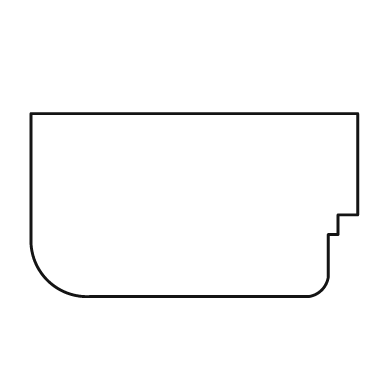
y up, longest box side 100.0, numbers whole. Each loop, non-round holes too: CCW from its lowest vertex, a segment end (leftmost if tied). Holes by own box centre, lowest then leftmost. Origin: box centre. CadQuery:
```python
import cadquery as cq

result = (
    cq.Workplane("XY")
    .moveTo(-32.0, -28.0)
    .lineTo(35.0, -28.0)
    .threePointArc((39.0, -26.0), (41.0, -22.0))
    .lineTo(41.0, -9.0)
    .lineTo(44.0, -9.0)
    .lineTo(44.0, -3.0)
    .lineTo(50.0, -3.0)
    .lineTo(50.0, 28.0)
    .lineTo(-50.0, 28.0)
    .lineTo(-50.0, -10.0)
    .threePointArc((-45.0, -23.0), (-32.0, -28.0))
    .close()
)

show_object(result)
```